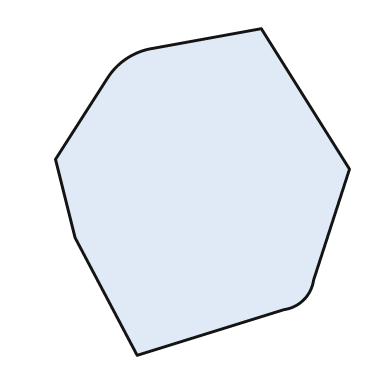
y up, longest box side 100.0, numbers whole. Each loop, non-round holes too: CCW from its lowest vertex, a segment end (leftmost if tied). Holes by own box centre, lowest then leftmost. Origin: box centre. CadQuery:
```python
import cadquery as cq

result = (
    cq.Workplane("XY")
    .moveTo(-20.0, -50.0)
    .lineTo(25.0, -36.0)
    .threePointArc((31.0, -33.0), (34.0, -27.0))
    .lineTo(45.0, 7.0)
    .lineTo(18.0, 50.0)
    .lineTo(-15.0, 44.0)
    .threePointArc((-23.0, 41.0), (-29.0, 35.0))
    .lineTo(-45.0, 10.0)
    .lineTo(-39.0, -14.0)
    .close()
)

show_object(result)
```